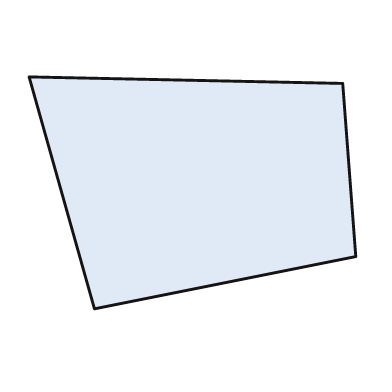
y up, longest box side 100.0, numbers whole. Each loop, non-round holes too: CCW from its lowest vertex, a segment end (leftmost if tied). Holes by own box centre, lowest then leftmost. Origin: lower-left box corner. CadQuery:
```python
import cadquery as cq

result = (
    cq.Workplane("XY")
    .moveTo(20.0, 0.0)
    .lineTo(100.0, 16.0)
    .lineTo(96.0, 69.0)
    .lineTo(0.0, 71.0)
    .close()
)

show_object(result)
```